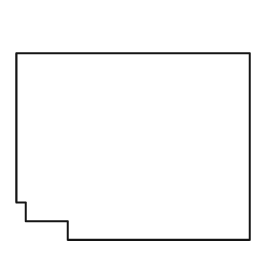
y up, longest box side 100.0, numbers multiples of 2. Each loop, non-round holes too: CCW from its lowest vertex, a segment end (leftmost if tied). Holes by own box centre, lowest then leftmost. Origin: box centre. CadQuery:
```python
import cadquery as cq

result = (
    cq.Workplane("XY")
    .moveTo(-28.0, -40.0)
    .lineTo(50.0, -40.0)
    .lineTo(50.0, 40.0)
    .lineTo(-50.0, 40.0)
    .lineTo(-50.0, -24.0)
    .lineTo(-46.0, -24.0)
    .lineTo(-46.0, -32.0)
    .lineTo(-28.0, -32.0)
    .close()
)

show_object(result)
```